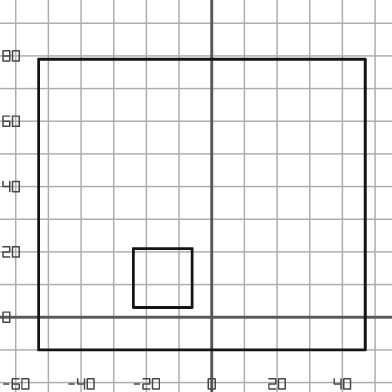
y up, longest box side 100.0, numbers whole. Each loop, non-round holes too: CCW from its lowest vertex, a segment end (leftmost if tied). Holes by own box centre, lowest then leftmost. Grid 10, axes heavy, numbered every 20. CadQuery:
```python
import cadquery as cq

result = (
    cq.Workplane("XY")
    .moveTo(-53.0, -10.0)
    .lineTo(47.0, -10.0)
    .lineTo(47.0, 79.0)
    .lineTo(-53.0, 79.0)
    .close()
    .moveTo(-24.0, 3.0)
    .lineTo(-6.0, 3.0)
    .lineTo(-6.0, 21.0)
    .lineTo(-24.0, 21.0)
    .close()
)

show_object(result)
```